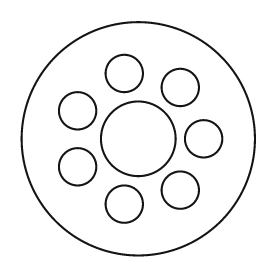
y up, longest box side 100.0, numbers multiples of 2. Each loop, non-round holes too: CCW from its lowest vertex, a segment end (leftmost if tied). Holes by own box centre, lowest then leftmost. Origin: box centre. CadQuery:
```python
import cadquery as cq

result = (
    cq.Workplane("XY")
    .moveTo(0.0, 0.0)
    .circle(50.0)
    .moveTo(-6.0, -28.0)
    .circle(8.0)
    .moveTo(18.0, -22.0)
    .circle(8.0)
    .moveTo(-26.0, -12.0)
    .circle(8.0)
    .moveTo(0.0, 0.0)
    .circle(16.0)
    .moveTo(28.0, 0.0)
    .circle(8.0)
    .moveTo(-26.0, 12.0)
    .circle(8.0)
    .moveTo(18.0, 22.0)
    .circle(8.0)
    .moveTo(-6.0, 28.0)
    .circle(8.0)
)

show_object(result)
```